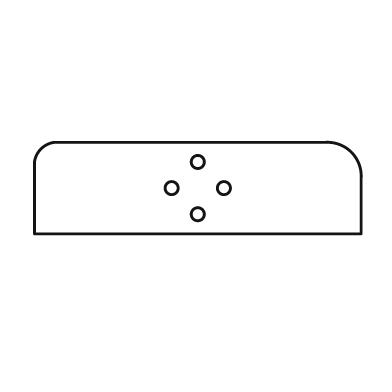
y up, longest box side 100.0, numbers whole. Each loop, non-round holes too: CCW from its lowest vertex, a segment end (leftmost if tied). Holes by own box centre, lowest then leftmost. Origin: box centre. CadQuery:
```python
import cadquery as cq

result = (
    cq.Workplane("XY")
    .moveTo(-50.0, -14.0)
    .lineTo(50.0, -14.0)
    .lineTo(50.0, 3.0)
    .threePointArc((47.0, 11.0), (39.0, 14.0))
    .lineTo(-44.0, 14.0)
    .threePointArc((-48.0, 12.0), (-50.0, 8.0))
    .close()
    .moveTo(0.0, -8.0)
    .circle(2.0)
    .moveTo(-8.0, 0.0)
    .circle(2.0)
    .moveTo(8.0, 0.0)
    .circle(2.0)
    .moveTo(0.0, 8.0)
    .circle(2.0)
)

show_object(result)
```